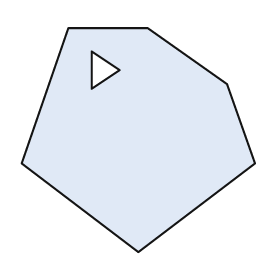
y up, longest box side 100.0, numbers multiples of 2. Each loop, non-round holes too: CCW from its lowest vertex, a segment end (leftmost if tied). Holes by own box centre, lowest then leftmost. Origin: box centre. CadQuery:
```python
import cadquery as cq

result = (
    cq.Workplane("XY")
    .moveTo(0.0, -48.0)
    .lineTo(50.0, -10.0)
    .lineTo(38.0, 24.0)
    .lineTo(4.0, 48.0)
    .lineTo(-30.0, 48.0)
    .lineTo(-50.0, -10.0)
    .close()
    .moveTo(-20.0, 22.0)
    .lineTo(-8.0, 30.0)
    .lineTo(-20.0, 38.0)
    .close()
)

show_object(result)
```